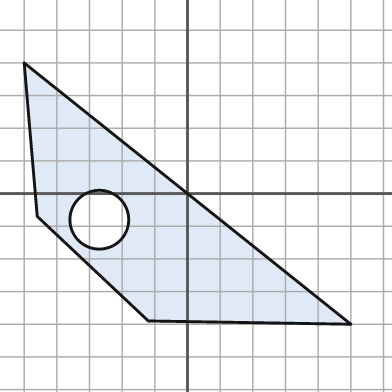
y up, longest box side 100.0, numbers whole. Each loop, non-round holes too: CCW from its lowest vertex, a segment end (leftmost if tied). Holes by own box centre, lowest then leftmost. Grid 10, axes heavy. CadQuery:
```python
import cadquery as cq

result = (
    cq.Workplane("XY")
    .moveTo(50.0, -40.0)
    .lineTo(-50.0, 40.0)
    .lineTo(-46.0, -7.0)
    .lineTo(-12.0, -39.0)
    .close()
    .moveTo(-27.0, -8.0)
    .circle(9.0)
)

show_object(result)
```